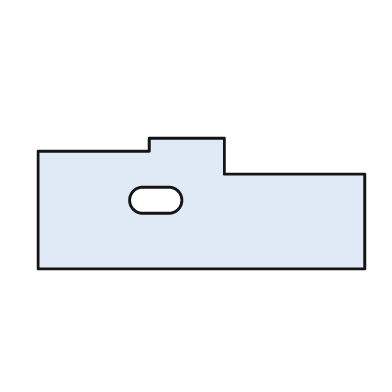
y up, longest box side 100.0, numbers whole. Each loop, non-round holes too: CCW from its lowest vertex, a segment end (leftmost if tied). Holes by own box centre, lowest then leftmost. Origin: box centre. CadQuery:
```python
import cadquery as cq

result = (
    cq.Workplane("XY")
    .moveTo(-50.0, -20.0)
    .lineTo(50.0, -20.0)
    .lineTo(50.0, 9.0)
    .lineTo(7.0, 9.0)
    .lineTo(7.0, 20.0)
    .lineTo(-16.0, 20.0)
    .lineTo(-16.0, 16.0)
    .lineTo(-50.0, 16.0)
    .close()
    .moveTo(-18.0, -3.0)
    .lineTo(-10.0, -3.0)
    .threePointArc((-6.0, 1.0), (-10.0, 5.0))
    .lineTo(-18.0, 5.0)
    .threePointArc((-22.0, 1.0), (-18.0, -3.0))
    .close()
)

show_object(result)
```